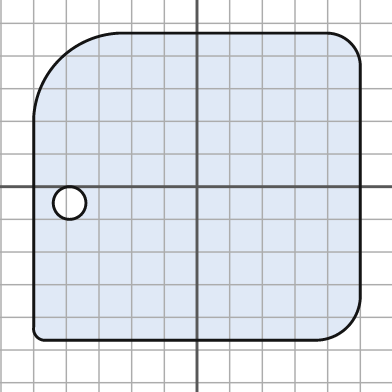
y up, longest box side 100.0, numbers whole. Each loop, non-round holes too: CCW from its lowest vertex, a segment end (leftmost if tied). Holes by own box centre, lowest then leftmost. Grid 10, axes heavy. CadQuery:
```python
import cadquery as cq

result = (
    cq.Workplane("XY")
    .moveTo(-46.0, -47.0)
    .lineTo(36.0, -47.0)
    .threePointArc((46.0, -43.0), (50.0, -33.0))
    .lineTo(50.0, 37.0)
    .threePointArc((47.0, 44.0), (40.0, 47.0))
    .lineTo(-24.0, 47.0)
    .threePointArc((-42.0, 39.0), (-50.0, 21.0))
    .lineTo(-50.0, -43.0)
    .threePointArc((-49.0, -46.0), (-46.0, -47.0))
    .close()
    .moveTo(-39.0, -5.0)
    .circle(5.0)
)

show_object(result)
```